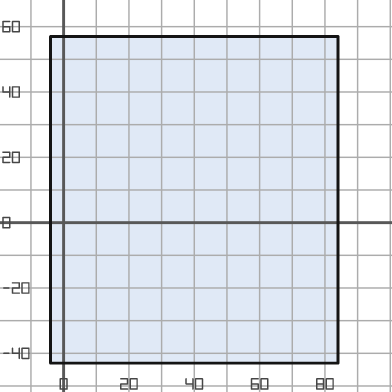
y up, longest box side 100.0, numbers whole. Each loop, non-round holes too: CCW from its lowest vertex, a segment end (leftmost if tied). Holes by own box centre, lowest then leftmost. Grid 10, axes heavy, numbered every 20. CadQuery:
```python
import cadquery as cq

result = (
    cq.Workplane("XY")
    .moveTo(-4.0, -43.0)
    .lineTo(84.0, -43.0)
    .lineTo(84.0, 57.0)
    .lineTo(-4.0, 57.0)
    .close()
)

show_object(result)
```